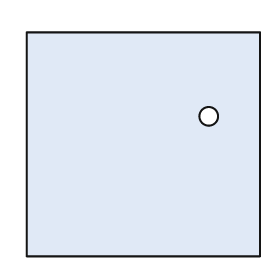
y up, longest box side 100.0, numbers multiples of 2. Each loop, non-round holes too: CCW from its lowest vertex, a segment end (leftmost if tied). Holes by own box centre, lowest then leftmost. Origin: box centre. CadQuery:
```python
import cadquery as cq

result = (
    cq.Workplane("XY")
    .moveTo(-50.0, -48.0)
    .lineTo(50.0, -48.0)
    .lineTo(50.0, 48.0)
    .lineTo(-50.0, 48.0)
    .close()
    .moveTo(28.0, 12.0)
    .circle(4.0)
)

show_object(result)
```